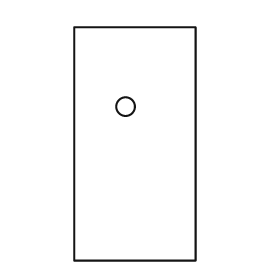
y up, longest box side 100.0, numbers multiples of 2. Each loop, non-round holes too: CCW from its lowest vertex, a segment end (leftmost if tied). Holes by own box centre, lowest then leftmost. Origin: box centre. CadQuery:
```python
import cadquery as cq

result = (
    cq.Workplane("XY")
    .moveTo(-26.0, -50.0)
    .lineTo(26.0, -50.0)
    .lineTo(26.0, 50.0)
    .lineTo(-26.0, 50.0)
    .close()
    .moveTo(-4.0, 16.0)
    .circle(4.0)
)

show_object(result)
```